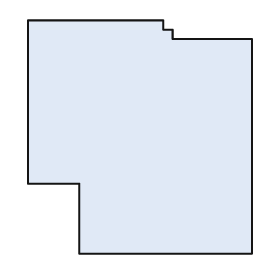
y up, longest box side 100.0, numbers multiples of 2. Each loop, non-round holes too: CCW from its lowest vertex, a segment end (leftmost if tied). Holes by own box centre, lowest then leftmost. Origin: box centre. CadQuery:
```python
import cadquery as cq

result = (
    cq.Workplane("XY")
    .moveTo(-26.0, -50.0)
    .lineTo(48.0, -50.0)
    .lineTo(48.0, 42.0)
    .lineTo(14.0, 42.0)
    .lineTo(14.0, 46.0)
    .lineTo(10.0, 46.0)
    .lineTo(10.0, 50.0)
    .lineTo(-48.0, 50.0)
    .lineTo(-48.0, -20.0)
    .lineTo(-26.0, -20.0)
    .close()
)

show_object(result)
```